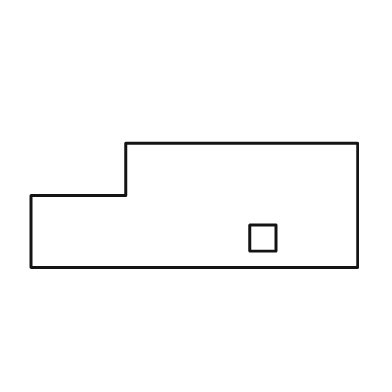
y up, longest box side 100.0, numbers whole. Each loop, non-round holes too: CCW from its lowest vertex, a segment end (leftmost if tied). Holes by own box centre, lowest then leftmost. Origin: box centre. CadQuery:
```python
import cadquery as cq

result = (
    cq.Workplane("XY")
    .moveTo(-50.0, -19.0)
    .lineTo(50.0, -19.0)
    .lineTo(50.0, 19.0)
    .lineTo(-21.0, 19.0)
    .lineTo(-21.0, 3.0)
    .lineTo(-50.0, 3.0)
    .close()
    .moveTo(17.0, -14.0)
    .lineTo(25.0, -14.0)
    .lineTo(25.0, -6.0)
    .lineTo(17.0, -6.0)
    .close()
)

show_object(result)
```